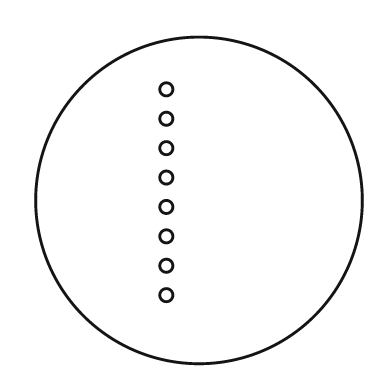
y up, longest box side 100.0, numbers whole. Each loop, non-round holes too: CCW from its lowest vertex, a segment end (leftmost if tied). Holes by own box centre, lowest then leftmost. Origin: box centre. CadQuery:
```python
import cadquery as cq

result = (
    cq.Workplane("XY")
    .moveTo(0.0, 0.0)
    .circle(50.0)
    .moveTo(-10.0, -29.0)
    .circle(2.0)
    .moveTo(-10.0, -20.0)
    .circle(2.0)
    .moveTo(-10.0, -11.0)
    .circle(2.0)
    .moveTo(-10.0, -2.0)
    .circle(2.0)
    .moveTo(-10.0, 7.0)
    .circle(2.0)
    .moveTo(-10.0, 16.0)
    .circle(2.0)
    .moveTo(-10.0, 25.0)
    .circle(2.0)
    .moveTo(-10.0, 34.0)
    .circle(2.0)
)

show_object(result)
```